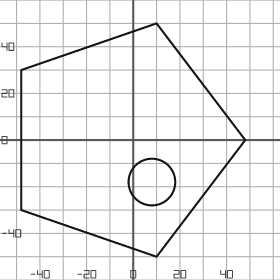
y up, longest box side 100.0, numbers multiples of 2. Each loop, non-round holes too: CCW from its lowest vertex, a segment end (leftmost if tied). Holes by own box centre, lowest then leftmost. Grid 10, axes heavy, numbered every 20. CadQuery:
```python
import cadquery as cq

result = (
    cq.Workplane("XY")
    .moveTo(10.0, -50.0)
    .lineTo(48.0, 0.0)
    .lineTo(10.0, 50.0)
    .lineTo(-48.0, 30.0)
    .lineTo(-48.0, -30.0)
    .close()
    .moveTo(8.0, -18.0)
    .circle(10.0)
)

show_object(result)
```